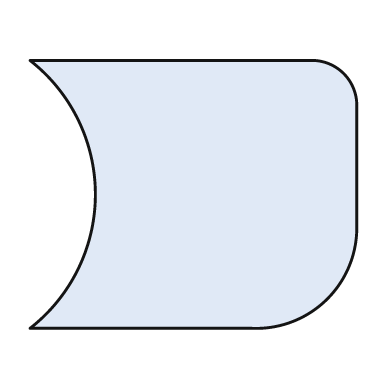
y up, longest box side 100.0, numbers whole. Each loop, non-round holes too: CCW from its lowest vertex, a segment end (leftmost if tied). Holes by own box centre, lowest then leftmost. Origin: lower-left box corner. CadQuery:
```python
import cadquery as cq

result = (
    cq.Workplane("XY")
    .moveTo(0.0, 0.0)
    .lineTo(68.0, 0.0)
    .threePointArc((91.0, 9.0), (100.0, 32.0))
    .lineTo(100.0, 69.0)
    .threePointArc((96.0, 78.0), (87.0, 82.0))
    .lineTo(0.0, 82.0)
    .threePointArc((20.0, 41.0), (0.0, 0.0))
    .close()
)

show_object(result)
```